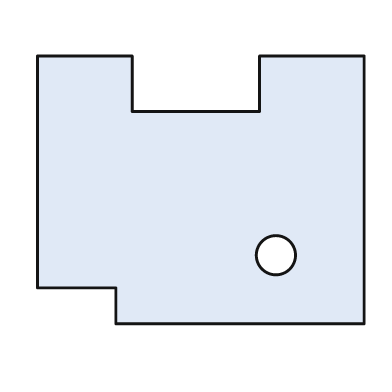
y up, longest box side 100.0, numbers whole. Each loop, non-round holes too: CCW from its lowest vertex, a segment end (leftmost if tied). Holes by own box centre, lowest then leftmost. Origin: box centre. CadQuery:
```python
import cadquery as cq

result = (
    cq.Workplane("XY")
    .moveTo(-26.0, -41.0)
    .lineTo(50.0, -41.0)
    .lineTo(50.0, 41.0)
    .lineTo(18.0, 41.0)
    .lineTo(18.0, 24.0)
    .lineTo(-21.0, 24.0)
    .lineTo(-21.0, 41.0)
    .lineTo(-50.0, 41.0)
    .lineTo(-50.0, -30.0)
    .lineTo(-26.0, -30.0)
    .close()
    .moveTo(23.0, -20.0)
    .circle(6.0)
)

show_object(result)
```